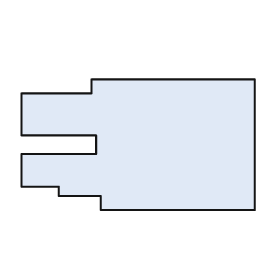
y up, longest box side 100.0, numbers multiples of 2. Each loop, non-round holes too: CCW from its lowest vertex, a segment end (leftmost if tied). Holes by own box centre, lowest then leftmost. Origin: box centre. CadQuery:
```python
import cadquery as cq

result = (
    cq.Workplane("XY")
    .moveTo(-16.0, -28.0)
    .lineTo(50.0, -28.0)
    .lineTo(50.0, 28.0)
    .lineTo(-20.0, 28.0)
    .lineTo(-20.0, 22.0)
    .lineTo(-50.0, 22.0)
    .lineTo(-50.0, 4.0)
    .lineTo(-18.0, 4.0)
    .lineTo(-18.0, -4.0)
    .lineTo(-50.0, -4.0)
    .lineTo(-50.0, -18.0)
    .lineTo(-34.0, -18.0)
    .lineTo(-34.0, -22.0)
    .lineTo(-16.0, -22.0)
    .close()
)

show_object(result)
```